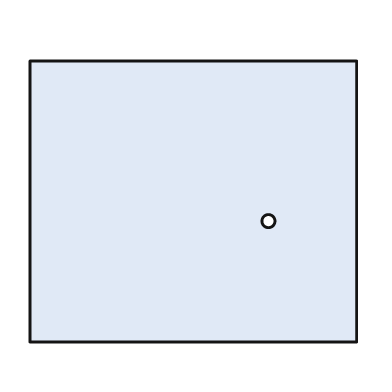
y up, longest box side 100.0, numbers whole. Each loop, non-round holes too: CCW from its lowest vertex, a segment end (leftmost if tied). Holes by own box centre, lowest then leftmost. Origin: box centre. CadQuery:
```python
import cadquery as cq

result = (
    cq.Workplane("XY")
    .moveTo(-50.0, -43.0)
    .lineTo(50.0, -43.0)
    .lineTo(50.0, 43.0)
    .lineTo(-50.0, 43.0)
    .close()
    .moveTo(23.0, -6.0)
    .circle(2.0)
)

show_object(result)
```